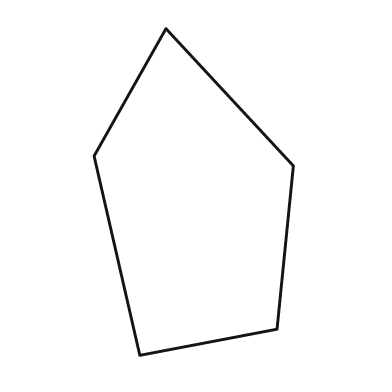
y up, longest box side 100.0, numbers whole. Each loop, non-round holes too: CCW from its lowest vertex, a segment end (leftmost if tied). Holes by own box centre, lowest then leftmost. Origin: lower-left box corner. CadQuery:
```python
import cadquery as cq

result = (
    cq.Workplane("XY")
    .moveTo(14.0, 0.0)
    .lineTo(56.0, 8.0)
    .lineTo(61.0, 58.0)
    .lineTo(22.0, 100.0)
    .lineTo(0.0, 61.0)
    .close()
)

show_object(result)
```